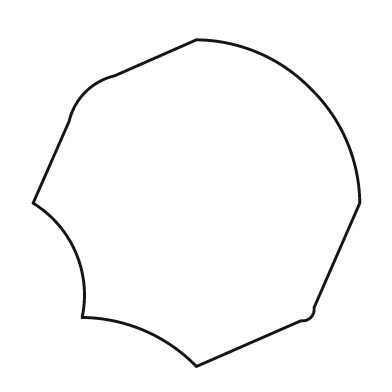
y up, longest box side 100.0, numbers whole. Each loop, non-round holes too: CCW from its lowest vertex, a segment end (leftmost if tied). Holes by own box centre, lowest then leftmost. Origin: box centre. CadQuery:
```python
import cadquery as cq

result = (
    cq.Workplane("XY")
    .moveTo(0.0, -50.0)
    .lineTo(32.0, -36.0)
    .threePointArc((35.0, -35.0), (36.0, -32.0))
    .lineTo(50.0, 0.0)
    .threePointArc((46.0, 19.0), (35.0, 35.0))
    .threePointArc((19.0, 46.0), (0.0, 50.0))
    .lineTo(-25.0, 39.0)
    .threePointArc((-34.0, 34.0), (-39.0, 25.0))
    .lineTo(-50.0, 0.0)
    .threePointArc((-37.0, -15.0), (-35.0, -35.0))
    .threePointArc((-16.0, -39.0), (0.0, -50.0))
    .close()
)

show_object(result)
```